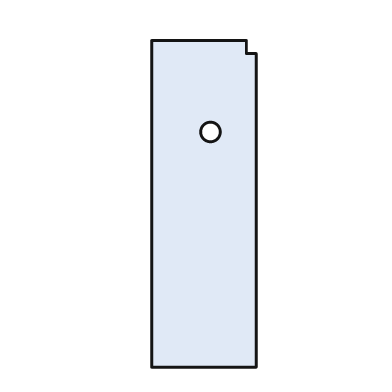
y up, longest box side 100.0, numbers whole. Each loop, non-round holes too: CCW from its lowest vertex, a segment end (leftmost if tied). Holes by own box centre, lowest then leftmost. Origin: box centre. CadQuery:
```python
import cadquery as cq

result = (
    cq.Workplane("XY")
    .moveTo(-16.0, -50.0)
    .lineTo(16.0, -50.0)
    .lineTo(16.0, 46.0)
    .lineTo(13.0, 46.0)
    .lineTo(13.0, 50.0)
    .lineTo(-16.0, 50.0)
    .close()
    .moveTo(2.0, 22.0)
    .circle(3.0)
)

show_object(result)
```